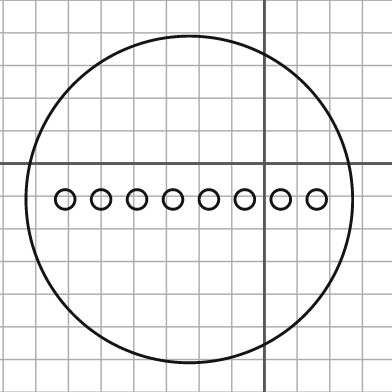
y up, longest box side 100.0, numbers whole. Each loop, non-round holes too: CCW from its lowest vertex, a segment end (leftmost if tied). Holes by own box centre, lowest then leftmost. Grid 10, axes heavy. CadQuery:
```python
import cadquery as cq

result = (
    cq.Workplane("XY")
    .moveTo(-23.0, -11.0)
    .circle(50.0)
    .moveTo(-61.0, -11.0)
    .circle(3.0)
    .moveTo(-50.0, -11.0)
    .circle(3.0)
    .moveTo(-39.0, -11.0)
    .circle(3.0)
    .moveTo(-28.0, -11.0)
    .circle(3.0)
    .moveTo(-17.0, -11.0)
    .circle(3.0)
    .moveTo(-6.0, -11.0)
    .circle(3.0)
    .moveTo(5.0, -11.0)
    .circle(3.0)
    .moveTo(16.0, -11.0)
    .circle(3.0)
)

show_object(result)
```